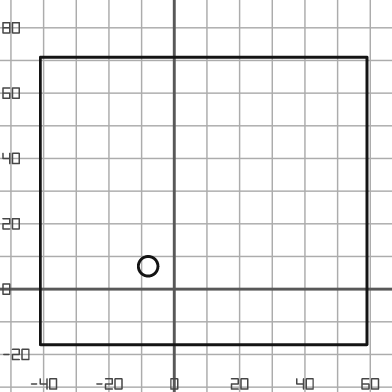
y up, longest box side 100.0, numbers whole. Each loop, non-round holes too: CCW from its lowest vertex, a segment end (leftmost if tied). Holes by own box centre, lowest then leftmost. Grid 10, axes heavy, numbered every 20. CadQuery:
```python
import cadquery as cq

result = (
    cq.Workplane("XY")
    .moveTo(-41.0, -17.0)
    .lineTo(59.0, -17.0)
    .lineTo(59.0, 71.0)
    .lineTo(-41.0, 71.0)
    .close()
    .moveTo(-8.0, 7.0)
    .circle(3.0)
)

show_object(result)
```